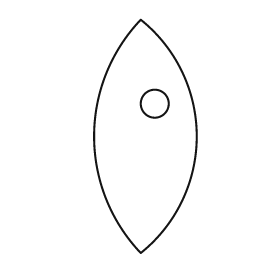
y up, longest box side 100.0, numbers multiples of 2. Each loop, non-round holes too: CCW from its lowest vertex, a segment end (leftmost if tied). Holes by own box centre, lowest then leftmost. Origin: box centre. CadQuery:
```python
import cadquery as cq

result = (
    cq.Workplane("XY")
    .moveTo(-2.0, -50.0)
    .threePointArc((22.0, 0.0), (-2.0, 50.0))
    .threePointArc((-22.0, 0.0), (-2.0, -50.0))
    .close()
    .moveTo(4.0, 14.0)
    .circle(6.0)
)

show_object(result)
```